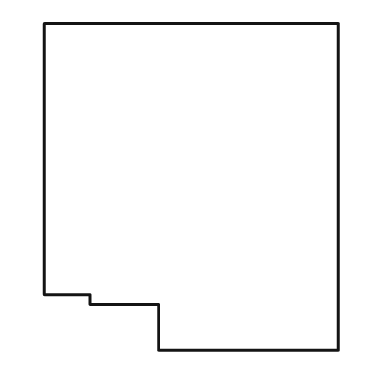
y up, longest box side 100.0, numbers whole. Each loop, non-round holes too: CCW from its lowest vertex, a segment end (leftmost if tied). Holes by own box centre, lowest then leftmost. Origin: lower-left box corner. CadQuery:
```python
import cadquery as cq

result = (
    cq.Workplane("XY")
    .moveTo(35.0, 0.0)
    .lineTo(90.0, 0.0)
    .lineTo(90.0, 100.0)
    .lineTo(0.0, 100.0)
    .lineTo(0.0, 17.0)
    .lineTo(14.0, 17.0)
    .lineTo(14.0, 14.0)
    .lineTo(35.0, 14.0)
    .close()
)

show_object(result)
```